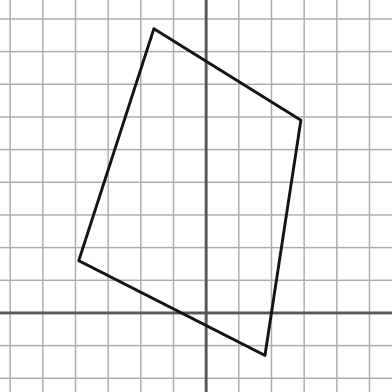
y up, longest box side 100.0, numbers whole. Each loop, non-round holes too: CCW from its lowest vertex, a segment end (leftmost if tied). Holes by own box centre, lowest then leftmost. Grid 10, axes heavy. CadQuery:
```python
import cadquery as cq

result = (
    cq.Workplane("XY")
    .moveTo(18.0, -13.0)
    .lineTo(29.0, 59.0)
    .lineTo(-16.0, 87.0)
    .lineTo(-39.0, 16.0)
    .close()
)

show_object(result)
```